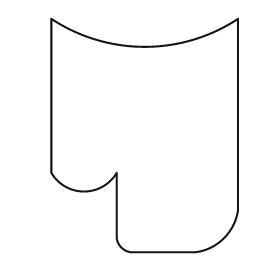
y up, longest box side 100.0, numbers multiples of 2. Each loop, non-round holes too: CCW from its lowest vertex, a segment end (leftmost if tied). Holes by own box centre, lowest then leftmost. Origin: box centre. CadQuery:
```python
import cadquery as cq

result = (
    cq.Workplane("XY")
    .moveTo(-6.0, -50.0)
    .lineTo(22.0, -50.0)
    .threePointArc((34.0, -44.0), (40.0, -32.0))
    .lineTo(40.0, 50.0)
    .threePointArc((0.0, 38.0), (-40.0, 50.0))
    .lineTo(-40.0, -16.0)
    .threePointArc((-26.0, -24.0), (-12.0, -16.0))
    .lineTo(-12.0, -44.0)
    .threePointArc((-10.0, -48.0), (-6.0, -50.0))
    .close()
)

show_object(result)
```